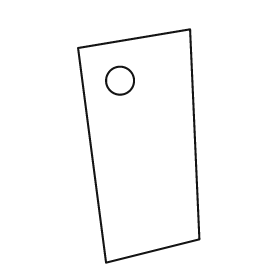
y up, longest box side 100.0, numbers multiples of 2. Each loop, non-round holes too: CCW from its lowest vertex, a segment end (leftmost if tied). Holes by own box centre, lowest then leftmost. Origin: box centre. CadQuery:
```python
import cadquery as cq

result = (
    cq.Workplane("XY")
    .moveTo(-14.0, -50.0)
    .lineTo(26.0, -40.0)
    .lineTo(22.0, 50.0)
    .lineTo(-26.0, 42.0)
    .close()
    .moveTo(-8.0, 28.0)
    .circle(6.0)
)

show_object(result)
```